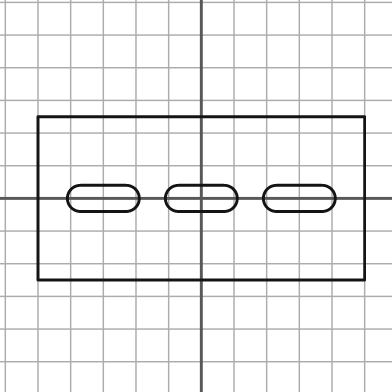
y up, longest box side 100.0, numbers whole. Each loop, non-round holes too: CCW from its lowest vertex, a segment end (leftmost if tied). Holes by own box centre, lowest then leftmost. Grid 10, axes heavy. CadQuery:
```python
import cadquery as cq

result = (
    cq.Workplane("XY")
    .moveTo(-50.0, -25.0)
    .lineTo(50.0, -25.0)
    .lineTo(50.0, 25.0)
    .lineTo(-50.0, 25.0)
    .close()
    .moveTo(-37.0, -4.0)
    .lineTo(-23.0, -4.0)
    .threePointArc((-19.0, 0.0), (-23.0, 4.0))
    .lineTo(-37.0, 4.0)
    .threePointArc((-41.0, 0.0), (-37.0, -4.0))
    .close()
    .moveTo(-7.0, -4.0)
    .lineTo(7.0, -4.0)
    .threePointArc((11.0, 0.0), (7.0, 4.0))
    .lineTo(-7.0, 4.0)
    .threePointArc((-11.0, 0.0), (-7.0, -4.0))
    .close()
    .moveTo(23.0, -4.0)
    .lineTo(37.0, -4.0)
    .threePointArc((41.0, 0.0), (37.0, 4.0))
    .lineTo(23.0, 4.0)
    .threePointArc((19.0, 0.0), (23.0, -4.0))
    .close()
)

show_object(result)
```